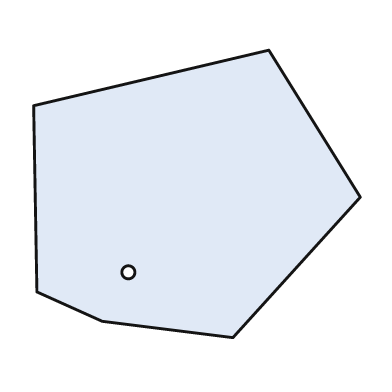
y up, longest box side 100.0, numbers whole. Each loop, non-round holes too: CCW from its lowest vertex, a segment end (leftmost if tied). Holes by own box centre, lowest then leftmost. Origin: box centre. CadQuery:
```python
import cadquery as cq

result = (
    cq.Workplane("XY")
    .moveTo(11.0, -44.0)
    .lineTo(50.0, -1.0)
    .lineTo(22.0, 44.0)
    .lineTo(-50.0, 27.0)
    .lineTo(-49.0, -30.0)
    .lineTo(-29.0, -39.0)
    .close()
    .moveTo(-21.0, -24.0)
    .circle(2.0)
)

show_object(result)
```